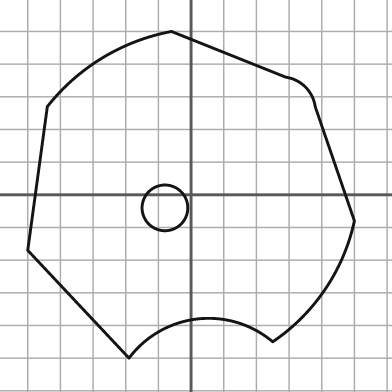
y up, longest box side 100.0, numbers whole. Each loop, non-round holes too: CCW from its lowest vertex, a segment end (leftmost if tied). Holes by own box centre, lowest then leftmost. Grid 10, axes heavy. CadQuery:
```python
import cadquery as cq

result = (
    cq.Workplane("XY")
    .moveTo(-19.0, -50.0)
    .threePointArc((2.0, -38.0), (25.0, -45.0))
    .threePointArc((41.0, -29.0), (50.0, -8.0))
    .lineTo(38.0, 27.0)
    .threePointArc((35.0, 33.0), (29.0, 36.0))
    .lineTo(-6.0, 50.0)
    .threePointArc((-27.0, 42.0), (-44.0, 27.0))
    .lineTo(-50.0, -17.0)
    .close()
    .moveTo(-8.0, -4.0)
    .circle(7.0)
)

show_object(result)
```